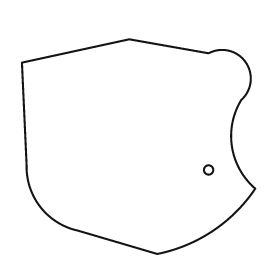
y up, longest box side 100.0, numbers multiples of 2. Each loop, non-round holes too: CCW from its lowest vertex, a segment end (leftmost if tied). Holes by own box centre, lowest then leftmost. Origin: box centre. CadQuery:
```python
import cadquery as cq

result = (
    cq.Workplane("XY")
    .moveTo(8.0, -46.0)
    .threePointArc((32.0, -36.0), (50.0, -18.0))
    .threePointArc((40.0, 0.0), (44.0, 20.0))
    .threePointArc((46.0, 36.0), (30.0, 40.0))
    .lineTo(-4.0, 46.0)
    .lineTo(-50.0, 36.0)
    .lineTo(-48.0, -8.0)
    .threePointArc((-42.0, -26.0), (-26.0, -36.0))
    .close()
    .moveTo(30.0, -10.0)
    .circle(2.0)
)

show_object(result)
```